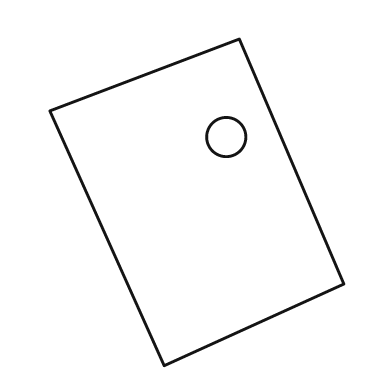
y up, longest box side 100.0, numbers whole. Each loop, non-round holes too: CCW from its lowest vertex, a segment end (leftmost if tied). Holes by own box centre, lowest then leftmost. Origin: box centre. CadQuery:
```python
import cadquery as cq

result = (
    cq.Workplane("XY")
    .moveTo(-10.0, -50.0)
    .lineTo(45.0, -25.0)
    .lineTo(13.0, 50.0)
    .lineTo(-45.0, 28.0)
    .close()
    .moveTo(9.0, 20.0)
    .circle(6.0)
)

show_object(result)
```